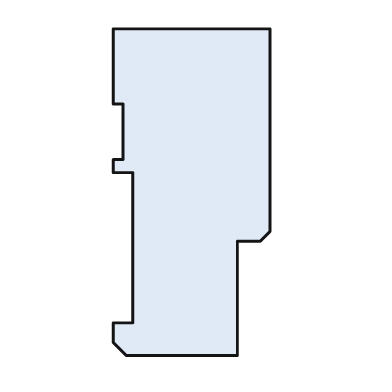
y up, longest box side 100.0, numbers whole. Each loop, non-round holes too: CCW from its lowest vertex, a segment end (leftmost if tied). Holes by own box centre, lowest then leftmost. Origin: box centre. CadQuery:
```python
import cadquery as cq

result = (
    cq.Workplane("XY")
    .moveTo(-20.0, -50.0)
    .lineTo(14.0, -50.0)
    .lineTo(14.0, -15.0)
    .lineTo(21.0, -15.0)
    .lineTo(24.0, -12.0)
    .lineTo(24.0, 50.0)
    .lineTo(-24.0, 50.0)
    .lineTo(-24.0, 27.0)
    .lineTo(-21.0, 27.0)
    .lineTo(-21.0, 10.0)
    .lineTo(-24.0, 10.0)
    .lineTo(-24.0, 6.0)
    .lineTo(-18.0, 6.0)
    .lineTo(-18.0, -40.0)
    .lineTo(-24.0, -40.0)
    .lineTo(-24.0, -46.0)
    .close()
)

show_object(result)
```